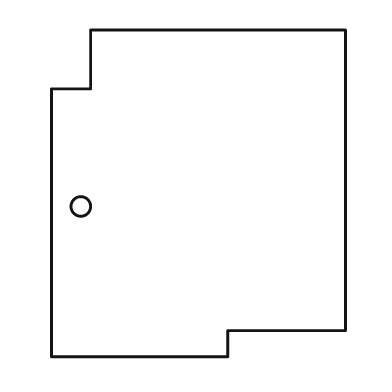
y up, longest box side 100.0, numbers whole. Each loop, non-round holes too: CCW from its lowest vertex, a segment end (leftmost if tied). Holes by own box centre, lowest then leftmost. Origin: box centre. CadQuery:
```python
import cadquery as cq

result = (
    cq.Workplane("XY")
    .moveTo(-45.0, -50.0)
    .lineTo(9.0, -50.0)
    .lineTo(9.0, -42.0)
    .lineTo(45.0, -42.0)
    .lineTo(45.0, 50.0)
    .lineTo(-33.0, 50.0)
    .lineTo(-33.0, 32.0)
    .lineTo(-45.0, 32.0)
    .close()
    .moveTo(-36.0, -4.0)
    .circle(3.0)
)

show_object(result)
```